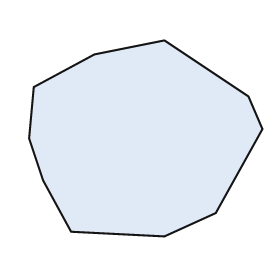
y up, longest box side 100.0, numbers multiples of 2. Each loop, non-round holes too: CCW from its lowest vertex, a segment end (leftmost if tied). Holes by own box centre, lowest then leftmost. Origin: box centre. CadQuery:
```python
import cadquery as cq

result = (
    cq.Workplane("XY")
    .moveTo(8.0, -42.0)
    .lineTo(30.0, -32.0)
    .lineTo(50.0, 4.0)
    .lineTo(44.0, 18.0)
    .lineTo(8.0, 42.0)
    .lineTo(-22.0, 36.0)
    .lineTo(-48.0, 22.0)
    .lineTo(-50.0, 0.0)
    .lineTo(-44.0, -18.0)
    .lineTo(-32.0, -40.0)
    .close()
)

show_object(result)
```